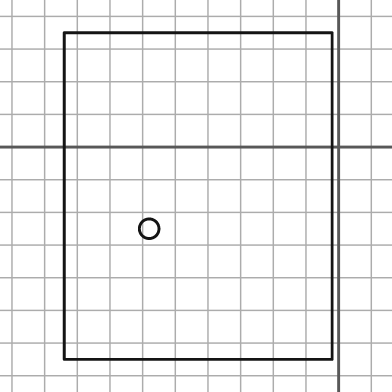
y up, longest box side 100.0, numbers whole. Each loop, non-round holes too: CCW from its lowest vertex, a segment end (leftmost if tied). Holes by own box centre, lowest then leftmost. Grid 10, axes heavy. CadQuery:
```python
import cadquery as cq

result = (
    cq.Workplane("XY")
    .moveTo(-84.0, -65.0)
    .lineTo(-2.0, -65.0)
    .lineTo(-2.0, 35.0)
    .lineTo(-84.0, 35.0)
    .close()
    .moveTo(-58.0, -25.0)
    .circle(3.0)
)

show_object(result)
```